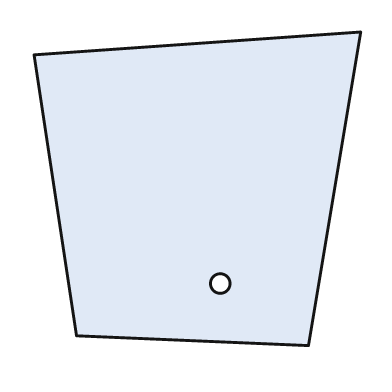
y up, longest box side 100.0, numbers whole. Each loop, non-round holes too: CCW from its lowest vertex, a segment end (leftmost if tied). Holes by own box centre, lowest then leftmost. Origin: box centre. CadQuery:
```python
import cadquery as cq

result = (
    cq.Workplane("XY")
    .moveTo(34.0, -48.0)
    .lineTo(50.0, 48.0)
    .lineTo(-50.0, 41.0)
    .lineTo(-37.0, -45.0)
    .close()
    .moveTo(7.0, -29.0)
    .circle(3.0)
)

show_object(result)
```